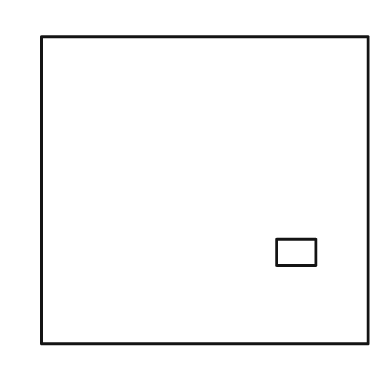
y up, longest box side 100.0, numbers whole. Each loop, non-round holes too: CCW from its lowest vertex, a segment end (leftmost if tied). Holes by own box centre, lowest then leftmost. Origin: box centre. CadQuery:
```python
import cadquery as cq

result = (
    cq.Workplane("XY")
    .moveTo(-50.0, -47.0)
    .lineTo(50.0, -47.0)
    .lineTo(50.0, 47.0)
    .lineTo(-50.0, 47.0)
    .close()
    .moveTo(22.0, -23.0)
    .lineTo(34.0, -23.0)
    .lineTo(34.0, -15.0)
    .lineTo(22.0, -15.0)
    .close()
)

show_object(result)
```